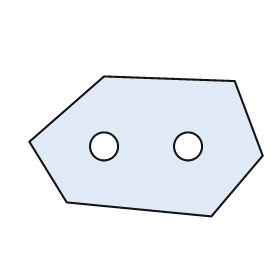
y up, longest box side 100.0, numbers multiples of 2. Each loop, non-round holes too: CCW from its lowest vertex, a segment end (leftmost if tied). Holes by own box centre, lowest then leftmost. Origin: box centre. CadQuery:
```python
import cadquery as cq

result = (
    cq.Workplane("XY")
    .moveTo(28.0, -30.0)
    .lineTo(50.0, -4.0)
    .lineTo(38.0, 28.0)
    .lineTo(-18.0, 30.0)
    .lineTo(-50.0, 2.0)
    .lineTo(-34.0, -24.0)
    .close()
    .moveTo(-18.0, 0.0)
    .circle(6.0)
    .moveTo(18.0, 0.0)
    .circle(6.0)
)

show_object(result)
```